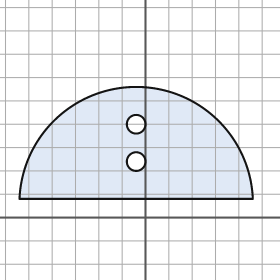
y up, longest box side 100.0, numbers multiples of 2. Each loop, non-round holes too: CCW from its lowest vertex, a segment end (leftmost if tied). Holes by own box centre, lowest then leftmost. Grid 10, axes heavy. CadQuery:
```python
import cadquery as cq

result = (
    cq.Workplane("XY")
    .moveTo(-54.0, 8.0)
    .lineTo(46.0, 8.0)
    .threePointArc((-4.0, 56.0), (-54.0, 8.0))
    .close()
    .moveTo(-4.0, 24.0)
    .circle(4.0)
    .moveTo(-4.0, 40.0)
    .circle(4.0)
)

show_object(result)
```